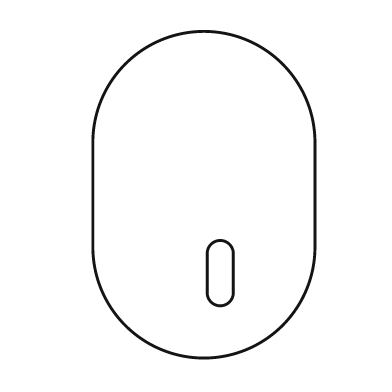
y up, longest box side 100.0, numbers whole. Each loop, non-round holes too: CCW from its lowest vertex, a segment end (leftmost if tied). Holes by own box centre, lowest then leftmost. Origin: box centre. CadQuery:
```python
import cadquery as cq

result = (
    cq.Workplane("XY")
    .moveTo(-34.0, -16.0)
    .threePointArc((0.0, -50.0), (34.0, -16.0))
    .lineTo(34.0, 16.0)
    .threePointArc((0.0, 50.0), (-34.0, 16.0))
    .close()
    .moveTo(1.0, -30.0)
    .threePointArc((5.0, -34.0), (9.0, -30.0))
    .lineTo(9.0, -18.0)
    .threePointArc((5.0, -14.0), (1.0, -18.0))
    .close()
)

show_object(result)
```